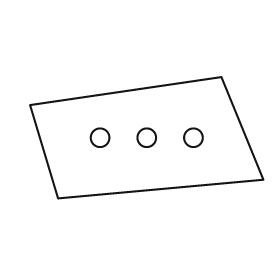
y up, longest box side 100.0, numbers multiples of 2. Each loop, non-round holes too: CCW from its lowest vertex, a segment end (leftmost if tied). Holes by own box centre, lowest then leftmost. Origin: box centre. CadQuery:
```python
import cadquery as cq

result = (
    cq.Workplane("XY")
    .moveTo(-38.0, -26.0)
    .lineTo(50.0, -18.0)
    .lineTo(32.0, 26.0)
    .lineTo(-50.0, 14.0)
    .close()
    .moveTo(-20.0, 0.0)
    .circle(4.0)
    .moveTo(0.0, 0.0)
    .circle(4.0)
    .moveTo(20.0, 0.0)
    .circle(4.0)
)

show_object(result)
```